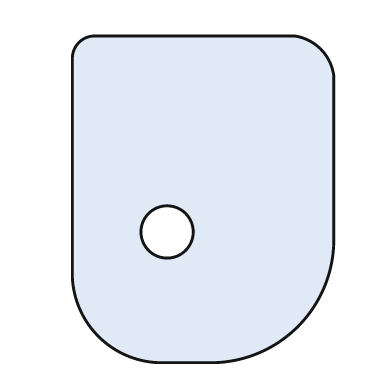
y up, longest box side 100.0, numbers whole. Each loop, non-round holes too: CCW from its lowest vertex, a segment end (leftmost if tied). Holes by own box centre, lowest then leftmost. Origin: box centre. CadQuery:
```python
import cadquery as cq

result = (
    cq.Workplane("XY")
    .moveTo(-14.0, -50.0)
    .lineTo(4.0, -50.0)
    .threePointArc((29.0, -39.0), (40.0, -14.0))
    .lineTo(40.0, 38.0)
    .threePointArc((36.0, 46.0), (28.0, 50.0))
    .lineTo(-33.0, 50.0)
    .threePointArc((-38.0, 48.0), (-40.0, 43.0))
    .lineTo(-40.0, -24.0)
    .threePointArc((-32.0, -42.0), (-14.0, -50.0))
    .close()
    .moveTo(-11.0, -10.0)
    .circle(8.0)
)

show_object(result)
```